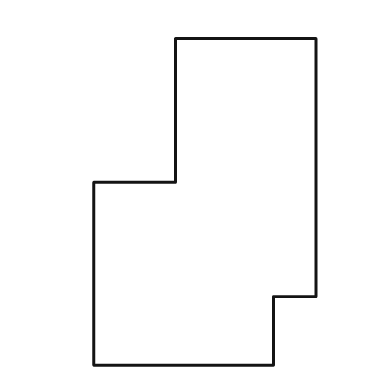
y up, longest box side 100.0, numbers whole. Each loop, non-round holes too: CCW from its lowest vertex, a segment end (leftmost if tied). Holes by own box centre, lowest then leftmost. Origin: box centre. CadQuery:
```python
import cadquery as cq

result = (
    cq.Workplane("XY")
    .moveTo(-34.0, -50.0)
    .lineTo(21.0, -50.0)
    .lineTo(21.0, -29.0)
    .lineTo(34.0, -29.0)
    .lineTo(34.0, 50.0)
    .lineTo(-9.0, 50.0)
    .lineTo(-9.0, 6.0)
    .lineTo(-34.0, 6.0)
    .close()
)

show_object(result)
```